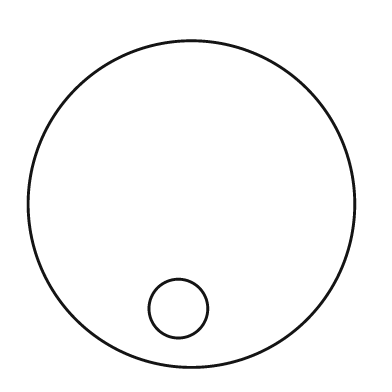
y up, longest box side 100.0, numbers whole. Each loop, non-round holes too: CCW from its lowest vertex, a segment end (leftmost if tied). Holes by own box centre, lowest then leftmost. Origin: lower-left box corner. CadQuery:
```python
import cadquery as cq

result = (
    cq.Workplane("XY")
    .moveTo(50.0, 50.0)
    .circle(50.0)
    .moveTo(46.0, 18.0)
    .circle(9.0)
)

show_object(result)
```